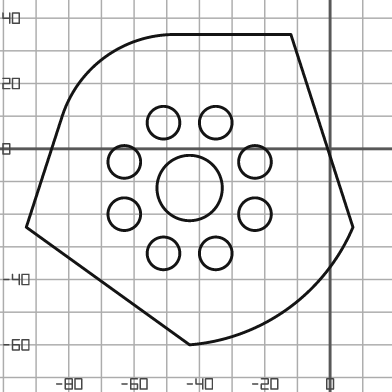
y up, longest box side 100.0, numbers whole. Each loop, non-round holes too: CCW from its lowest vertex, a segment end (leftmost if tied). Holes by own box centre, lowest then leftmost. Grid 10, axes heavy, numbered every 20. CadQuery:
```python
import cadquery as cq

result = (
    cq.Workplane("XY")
    .moveTo(-43.0, -60.0)
    .threePointArc((-13.0, -49.0), (7.0, -24.0))
    .lineTo(-12.0, 35.0)
    .lineTo(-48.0, 35.0)
    .threePointArc((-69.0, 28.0), (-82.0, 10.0))
    .lineTo(-93.0, -24.0)
    .close()
    .moveTo(-51.0, -32.0)
    .circle(5.0)
    .moveTo(-35.0, -32.0)
    .circle(5.0)
    .moveTo(-63.0, -20.0)
    .circle(5.0)
    .moveTo(-23.0, -20.0)
    .circle(5.0)
    .moveTo(-43.0, -12.0)
    .circle(10.0)
    .moveTo(-63.0, -4.0)
    .circle(5.0)
    .moveTo(-23.0, -4.0)
    .circle(5.0)
    .moveTo(-51.0, 8.0)
    .circle(5.0)
    .moveTo(-35.0, 8.0)
    .circle(5.0)
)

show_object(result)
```